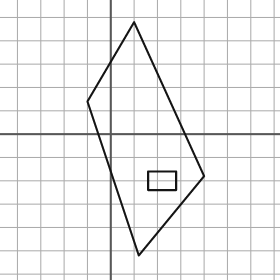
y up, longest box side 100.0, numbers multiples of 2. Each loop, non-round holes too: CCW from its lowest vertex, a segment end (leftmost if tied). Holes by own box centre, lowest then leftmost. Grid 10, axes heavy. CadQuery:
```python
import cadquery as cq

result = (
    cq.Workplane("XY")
    .moveTo(12.0, -52.0)
    .lineTo(40.0, -18.0)
    .lineTo(10.0, 48.0)
    .lineTo(-10.0, 14.0)
    .close()
    .moveTo(16.0, -24.0)
    .lineTo(28.0, -24.0)
    .lineTo(28.0, -16.0)
    .lineTo(16.0, -16.0)
    .close()
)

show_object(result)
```